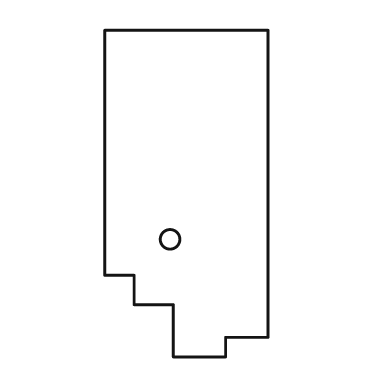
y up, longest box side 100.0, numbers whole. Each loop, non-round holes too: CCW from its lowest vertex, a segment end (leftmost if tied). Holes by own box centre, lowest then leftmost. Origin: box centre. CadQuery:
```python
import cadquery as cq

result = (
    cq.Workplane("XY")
    .moveTo(-4.0, -50.0)
    .lineTo(12.0, -50.0)
    .lineTo(12.0, -44.0)
    .lineTo(25.0, -44.0)
    .lineTo(25.0, 50.0)
    .lineTo(-25.0, 50.0)
    .lineTo(-25.0, -25.0)
    .lineTo(-16.0, -25.0)
    .lineTo(-16.0, -34.0)
    .lineTo(-4.0, -34.0)
    .close()
    .moveTo(-5.0, -14.0)
    .circle(3.0)
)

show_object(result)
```